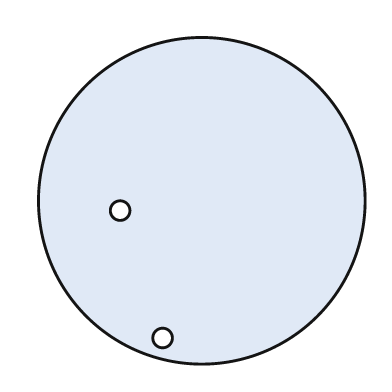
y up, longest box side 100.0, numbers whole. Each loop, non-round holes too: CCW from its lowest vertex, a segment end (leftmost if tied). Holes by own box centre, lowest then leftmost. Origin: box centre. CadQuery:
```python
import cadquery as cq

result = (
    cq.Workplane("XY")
    .moveTo(0.0, 0.0)
    .circle(50.0)
    .moveTo(-12.0, -42.0)
    .circle(3.0)
    .moveTo(-25.0, -3.0)
    .circle(3.0)
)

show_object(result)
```